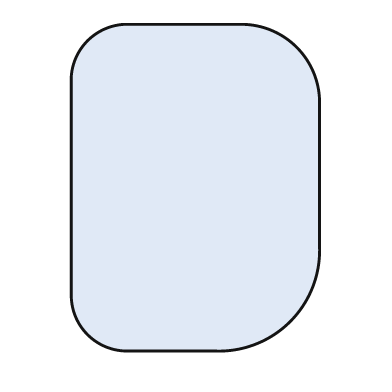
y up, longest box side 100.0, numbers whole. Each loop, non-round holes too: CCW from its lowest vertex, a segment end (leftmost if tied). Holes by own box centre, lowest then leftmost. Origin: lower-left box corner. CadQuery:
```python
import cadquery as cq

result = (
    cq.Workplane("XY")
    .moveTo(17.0, 0.0)
    .lineTo(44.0, 0.0)
    .threePointArc((67.0, 9.0), (76.0, 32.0))
    .lineTo(76.0, 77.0)
    .threePointArc((69.0, 93.0), (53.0, 100.0))
    .lineTo(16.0, 100.0)
    .threePointArc((5.0, 95.0), (0.0, 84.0))
    .lineTo(0.0, 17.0)
    .threePointArc((5.0, 5.0), (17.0, 0.0))
    .close()
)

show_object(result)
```